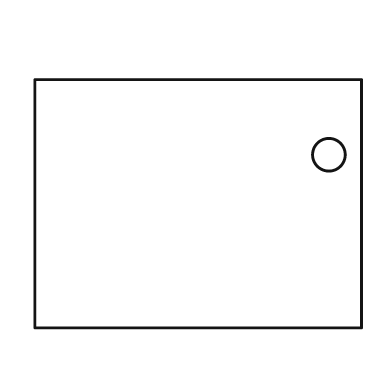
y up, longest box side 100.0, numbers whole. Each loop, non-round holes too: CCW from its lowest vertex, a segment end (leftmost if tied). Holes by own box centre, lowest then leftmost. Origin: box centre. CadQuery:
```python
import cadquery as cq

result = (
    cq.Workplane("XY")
    .moveTo(-50.0, -38.0)
    .lineTo(50.0, -38.0)
    .lineTo(50.0, 38.0)
    .lineTo(-50.0, 38.0)
    .close()
    .moveTo(40.0, 15.0)
    .circle(5.0)
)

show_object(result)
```